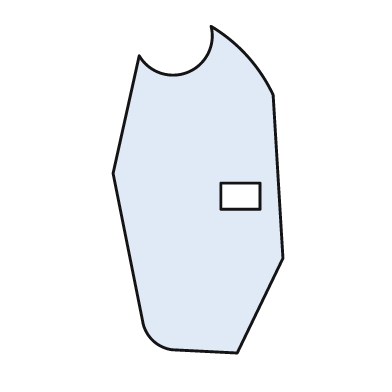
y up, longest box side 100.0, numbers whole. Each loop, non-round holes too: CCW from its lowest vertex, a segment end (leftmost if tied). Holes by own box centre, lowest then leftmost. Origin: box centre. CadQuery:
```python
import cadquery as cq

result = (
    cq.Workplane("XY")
    .moveTo(12.0, -50.0)
    .lineTo(26.0, -21.0)
    .lineTo(23.0, 29.0)
    .threePointArc((15.0, 41.0), (4.0, 50.0))
    .threePointArc((-3.0, 36.0), (-18.0, 41.0))
    .lineTo(-26.0, 5.0)
    .lineTo(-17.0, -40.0)
    .threePointArc((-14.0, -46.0), (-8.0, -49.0))
    .close()
    .moveTo(7.0, -6.0)
    .lineTo(19.0, -6.0)
    .lineTo(19.0, 2.0)
    .lineTo(7.0, 2.0)
    .close()
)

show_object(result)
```